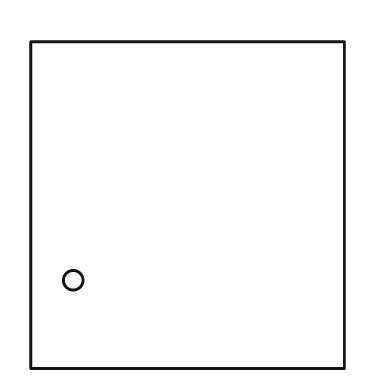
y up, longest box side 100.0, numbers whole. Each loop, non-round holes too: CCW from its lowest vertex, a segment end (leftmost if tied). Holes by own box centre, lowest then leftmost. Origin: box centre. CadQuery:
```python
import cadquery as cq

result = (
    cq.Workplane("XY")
    .moveTo(-48.0, -50.0)
    .lineTo(48.0, -50.0)
    .lineTo(48.0, 50.0)
    .lineTo(-48.0, 50.0)
    .close()
    .moveTo(-35.0, -23.0)
    .circle(3.0)
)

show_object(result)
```